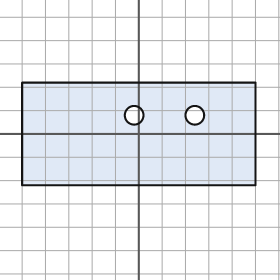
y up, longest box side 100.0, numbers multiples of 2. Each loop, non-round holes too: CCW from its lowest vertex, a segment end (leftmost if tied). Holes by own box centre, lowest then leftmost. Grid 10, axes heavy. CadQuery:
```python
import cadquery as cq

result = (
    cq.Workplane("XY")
    .moveTo(-50.0, -22.0)
    .lineTo(50.0, -22.0)
    .lineTo(50.0, 22.0)
    .lineTo(-50.0, 22.0)
    .close()
    .moveTo(-2.0, 8.0)
    .circle(4.0)
    .moveTo(24.0, 8.0)
    .circle(4.0)
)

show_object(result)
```